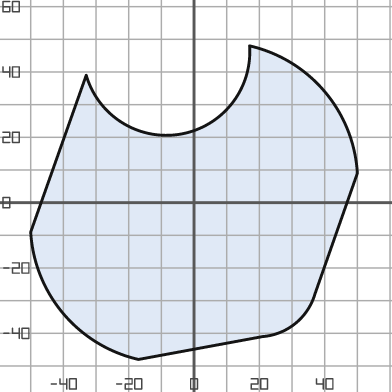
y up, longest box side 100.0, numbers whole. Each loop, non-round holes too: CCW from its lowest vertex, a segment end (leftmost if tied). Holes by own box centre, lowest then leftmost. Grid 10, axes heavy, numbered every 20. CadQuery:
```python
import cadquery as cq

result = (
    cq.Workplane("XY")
    .moveTo(-17.0, -48.0)
    .lineTo(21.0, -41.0)
    .threePointArc((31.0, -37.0), (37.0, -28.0))
    .lineTo(50.0, 9.0)
    .threePointArc((40.0, 34.0), (17.0, 48.0))
    .threePointArc((-4.0, 21.0), (-33.0, 39.0))
    .lineTo(-50.0, -9.0)
    .threePointArc((-40.0, -34.0), (-17.0, -48.0))
    .close()
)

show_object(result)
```